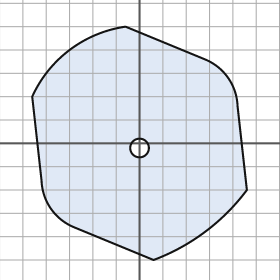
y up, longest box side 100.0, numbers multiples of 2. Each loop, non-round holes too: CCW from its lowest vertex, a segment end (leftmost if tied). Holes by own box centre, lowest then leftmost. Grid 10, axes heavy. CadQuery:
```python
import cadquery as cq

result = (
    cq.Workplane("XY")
    .moveTo(6.0, -50.0)
    .threePointArc((28.0, -38.0), (46.0, -20.0))
    .lineTo(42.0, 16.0)
    .threePointArc((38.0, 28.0), (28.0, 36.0))
    .lineTo(-6.0, 50.0)
    .threePointArc((-30.0, 40.0), (-46.0, 20.0))
    .lineTo(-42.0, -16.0)
    .threePointArc((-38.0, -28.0), (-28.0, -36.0))
    .close()
    .moveTo(0.0, -2.0)
    .circle(4.0)
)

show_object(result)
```